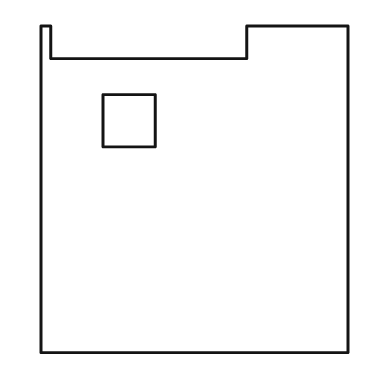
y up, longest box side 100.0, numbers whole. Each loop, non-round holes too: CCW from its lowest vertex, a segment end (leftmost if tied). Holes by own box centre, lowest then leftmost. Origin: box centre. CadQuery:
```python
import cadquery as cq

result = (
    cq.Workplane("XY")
    .moveTo(-47.0, -50.0)
    .lineTo(47.0, -50.0)
    .lineTo(47.0, 50.0)
    .lineTo(16.0, 50.0)
    .lineTo(16.0, 40.0)
    .lineTo(-44.0, 40.0)
    .lineTo(-44.0, 50.0)
    .lineTo(-47.0, 50.0)
    .close()
    .moveTo(-28.0, 13.0)
    .lineTo(-12.0, 13.0)
    .lineTo(-12.0, 29.0)
    .lineTo(-28.0, 29.0)
    .close()
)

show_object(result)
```